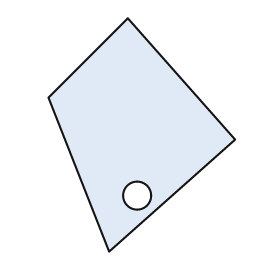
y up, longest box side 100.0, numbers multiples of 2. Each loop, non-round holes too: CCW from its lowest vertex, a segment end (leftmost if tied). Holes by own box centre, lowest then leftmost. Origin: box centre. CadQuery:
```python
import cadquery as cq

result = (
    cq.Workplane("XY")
    .moveTo(-14.0, -50.0)
    .lineTo(40.0, -2.0)
    .lineTo(-6.0, 50.0)
    .lineTo(-40.0, 16.0)
    .close()
    .moveTo(-2.0, -26.0)
    .circle(6.0)
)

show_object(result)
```